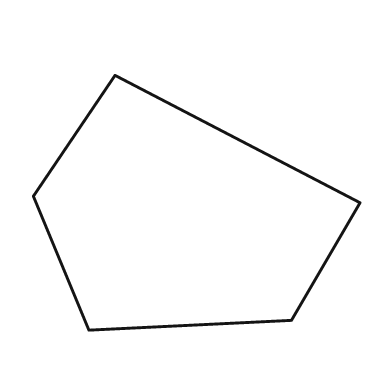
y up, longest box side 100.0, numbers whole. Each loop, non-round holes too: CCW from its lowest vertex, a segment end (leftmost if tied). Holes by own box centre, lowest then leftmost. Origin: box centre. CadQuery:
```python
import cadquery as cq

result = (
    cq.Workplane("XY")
    .moveTo(-33.0, -39.0)
    .lineTo(29.0, -36.0)
    .lineTo(50.0, 0.0)
    .lineTo(-25.0, 39.0)
    .lineTo(-50.0, 2.0)
    .close()
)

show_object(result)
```